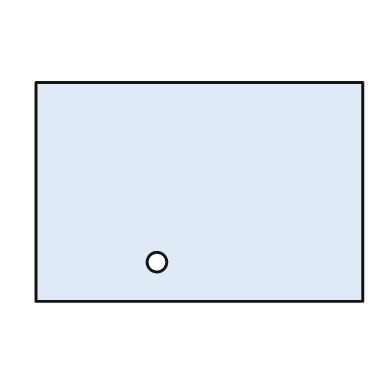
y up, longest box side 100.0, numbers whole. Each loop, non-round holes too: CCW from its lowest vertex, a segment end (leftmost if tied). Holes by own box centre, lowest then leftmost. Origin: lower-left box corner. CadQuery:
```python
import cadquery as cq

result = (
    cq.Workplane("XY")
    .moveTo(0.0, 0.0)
    .lineTo(100.0, 0.0)
    .lineTo(100.0, 67.0)
    .lineTo(0.0, 67.0)
    .close()
    .moveTo(37.0, 12.0)
    .circle(3.0)
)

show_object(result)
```